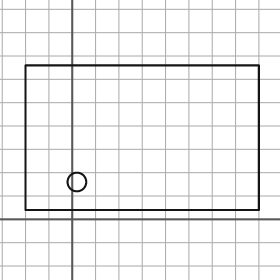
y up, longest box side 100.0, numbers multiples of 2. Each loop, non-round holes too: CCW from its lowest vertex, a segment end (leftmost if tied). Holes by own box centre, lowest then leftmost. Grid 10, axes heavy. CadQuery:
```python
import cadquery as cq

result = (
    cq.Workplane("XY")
    .moveTo(-20.0, 4.0)
    .lineTo(80.0, 4.0)
    .lineTo(80.0, 66.0)
    .lineTo(-20.0, 66.0)
    .close()
    .moveTo(2.0, 16.0)
    .circle(4.0)
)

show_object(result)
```